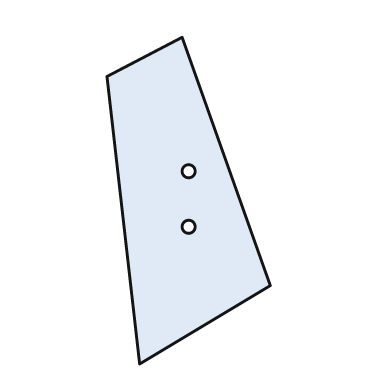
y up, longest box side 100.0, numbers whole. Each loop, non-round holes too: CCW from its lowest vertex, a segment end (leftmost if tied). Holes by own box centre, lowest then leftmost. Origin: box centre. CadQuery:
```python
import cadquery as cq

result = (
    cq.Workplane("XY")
    .moveTo(-15.0, -50.0)
    .lineTo(25.0, -26.0)
    .lineTo(-2.0, 50.0)
    .lineTo(-25.0, 38.0)
    .close()
    .moveTo(0.0, -8.0)
    .circle(2.0)
    .moveTo(0.0, 9.0)
    .circle(2.0)
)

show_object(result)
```